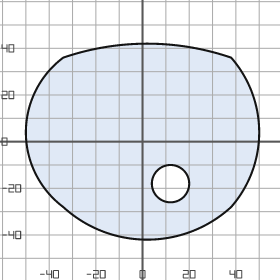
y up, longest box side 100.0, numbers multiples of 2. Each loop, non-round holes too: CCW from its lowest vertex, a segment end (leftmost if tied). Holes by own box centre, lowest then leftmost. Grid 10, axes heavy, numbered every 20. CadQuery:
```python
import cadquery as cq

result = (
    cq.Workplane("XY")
    .moveTo(-34.0, -28.0)
    .threePointArc((2.0, -42.0), (38.0, -28.0))
    .threePointArc((50.0, 4.0), (38.0, 36.0))
    .threePointArc((2.0, 42.0), (-34.0, 36.0))
    .threePointArc((-50.0, 4.0), (-34.0, -28.0))
    .close()
    .moveTo(12.0, -18.0)
    .circle(8.0)
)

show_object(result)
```